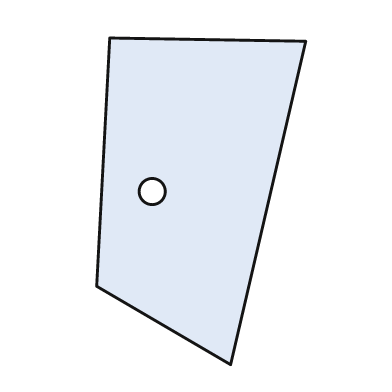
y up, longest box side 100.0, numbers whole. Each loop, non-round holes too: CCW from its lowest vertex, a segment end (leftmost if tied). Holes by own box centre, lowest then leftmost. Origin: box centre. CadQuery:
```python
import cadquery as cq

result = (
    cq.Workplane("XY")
    .moveTo(9.0, -50.0)
    .lineTo(32.0, 49.0)
    .lineTo(-28.0, 50.0)
    .lineTo(-32.0, -26.0)
    .close()
    .moveTo(-15.0, 3.0)
    .circle(4.0)
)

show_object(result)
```